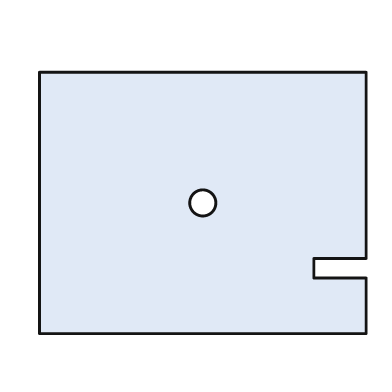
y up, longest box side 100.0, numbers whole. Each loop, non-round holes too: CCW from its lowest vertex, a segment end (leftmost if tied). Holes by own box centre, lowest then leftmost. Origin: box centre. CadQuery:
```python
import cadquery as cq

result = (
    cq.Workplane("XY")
    .moveTo(-50.0, -40.0)
    .lineTo(50.0, -40.0)
    .lineTo(50.0, -23.0)
    .lineTo(34.0, -23.0)
    .lineTo(34.0, -17.0)
    .lineTo(50.0, -17.0)
    .lineTo(50.0, 40.0)
    .lineTo(-50.0, 40.0)
    .close()
    .moveTo(0.0, 0.0)
    .circle(4.0)
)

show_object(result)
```